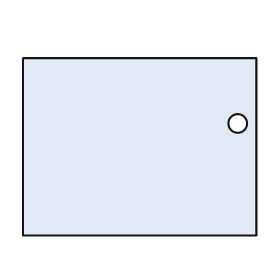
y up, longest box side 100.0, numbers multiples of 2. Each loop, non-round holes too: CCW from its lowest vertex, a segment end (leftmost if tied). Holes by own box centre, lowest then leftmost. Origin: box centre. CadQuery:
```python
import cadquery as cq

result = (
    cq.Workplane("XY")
    .moveTo(-50.0, -38.0)
    .lineTo(50.0, -38.0)
    .lineTo(50.0, 38.0)
    .lineTo(-50.0, 38.0)
    .close()
    .moveTo(42.0, 10.0)
    .circle(4.0)
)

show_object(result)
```